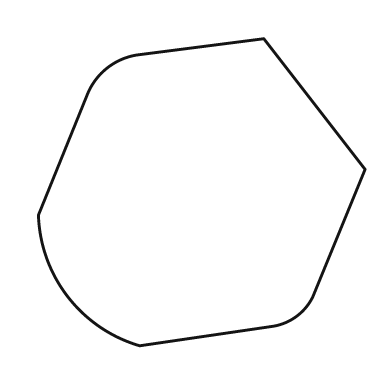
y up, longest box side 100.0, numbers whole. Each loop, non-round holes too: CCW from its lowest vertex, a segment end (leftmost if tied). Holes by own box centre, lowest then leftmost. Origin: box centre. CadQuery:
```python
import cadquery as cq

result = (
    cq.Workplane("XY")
    .moveTo(-19.0, -47.0)
    .lineTo(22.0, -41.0)
    .threePointArc((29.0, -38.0), (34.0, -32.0))
    .lineTo(50.0, 7.0)
    .lineTo(19.0, 47.0)
    .lineTo(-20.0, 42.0)
    .threePointArc((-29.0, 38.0), (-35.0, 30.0))
    .lineTo(-50.0, -7.0)
    .threePointArc((-41.0, -32.0), (-19.0, -47.0))
    .close()
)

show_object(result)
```